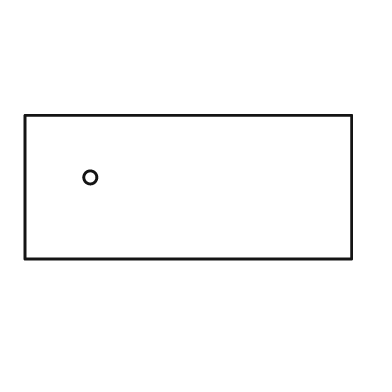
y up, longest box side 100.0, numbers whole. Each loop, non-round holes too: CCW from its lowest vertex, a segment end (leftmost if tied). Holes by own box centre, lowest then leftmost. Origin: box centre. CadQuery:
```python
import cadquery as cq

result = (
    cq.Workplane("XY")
    .moveTo(-50.0, -22.0)
    .lineTo(50.0, -22.0)
    .lineTo(50.0, 22.0)
    .lineTo(-50.0, 22.0)
    .close()
    .moveTo(-30.0, 3.0)
    .circle(2.0)
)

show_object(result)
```